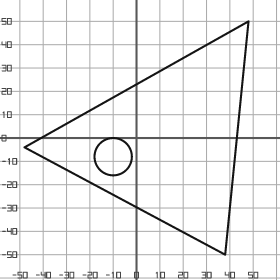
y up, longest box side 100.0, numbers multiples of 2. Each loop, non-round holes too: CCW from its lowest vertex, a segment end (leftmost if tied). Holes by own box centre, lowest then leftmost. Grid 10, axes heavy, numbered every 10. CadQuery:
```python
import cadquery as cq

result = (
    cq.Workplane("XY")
    .moveTo(38.0, -50.0)
    .lineTo(48.0, 50.0)
    .lineTo(-48.0, -4.0)
    .close()
    .moveTo(-10.0, -8.0)
    .circle(8.0)
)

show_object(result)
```